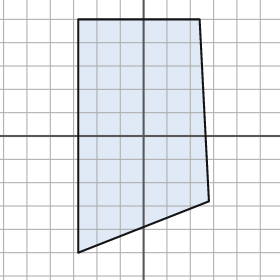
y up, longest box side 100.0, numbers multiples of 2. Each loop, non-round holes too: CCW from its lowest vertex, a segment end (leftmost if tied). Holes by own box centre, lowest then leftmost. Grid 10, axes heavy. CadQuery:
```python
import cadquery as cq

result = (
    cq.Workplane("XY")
    .moveTo(-28.0, -50.0)
    .lineTo(28.0, -28.0)
    .lineTo(24.0, 50.0)
    .lineTo(-28.0, 50.0)
    .close()
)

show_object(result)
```